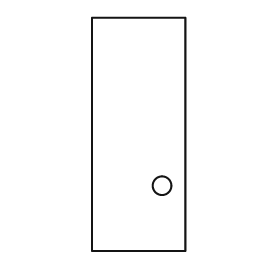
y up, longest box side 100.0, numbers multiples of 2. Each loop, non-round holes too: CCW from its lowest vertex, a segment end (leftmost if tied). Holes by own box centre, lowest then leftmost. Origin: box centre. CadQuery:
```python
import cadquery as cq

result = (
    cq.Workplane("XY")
    .moveTo(-20.0, -50.0)
    .lineTo(20.0, -50.0)
    .lineTo(20.0, 50.0)
    .lineTo(-20.0, 50.0)
    .close()
    .moveTo(10.0, -22.0)
    .circle(4.0)
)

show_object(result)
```